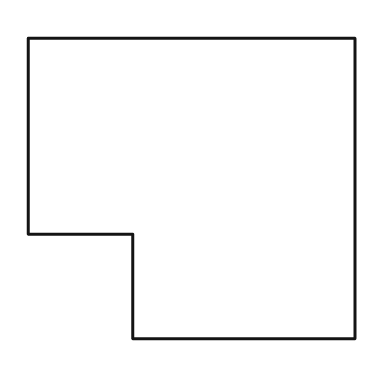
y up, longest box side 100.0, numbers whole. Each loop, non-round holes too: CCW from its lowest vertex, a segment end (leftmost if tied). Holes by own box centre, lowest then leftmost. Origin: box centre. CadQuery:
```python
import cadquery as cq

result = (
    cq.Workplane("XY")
    .moveTo(-18.0, -46.0)
    .lineTo(50.0, -46.0)
    .lineTo(50.0, 46.0)
    .lineTo(-50.0, 46.0)
    .lineTo(-50.0, -14.0)
    .lineTo(-18.0, -14.0)
    .close()
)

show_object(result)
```